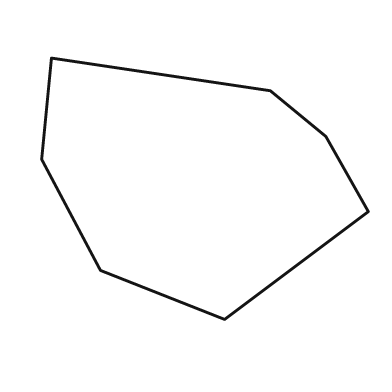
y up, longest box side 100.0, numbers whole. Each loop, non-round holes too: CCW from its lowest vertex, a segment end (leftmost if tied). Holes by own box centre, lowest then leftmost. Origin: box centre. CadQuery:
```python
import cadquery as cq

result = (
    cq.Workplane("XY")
    .moveTo(6.0, -40.0)
    .lineTo(50.0, -7.0)
    .lineTo(37.0, 16.0)
    .lineTo(20.0, 30.0)
    .lineTo(-47.0, 40.0)
    .lineTo(-50.0, 9.0)
    .lineTo(-32.0, -25.0)
    .close()
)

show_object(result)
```